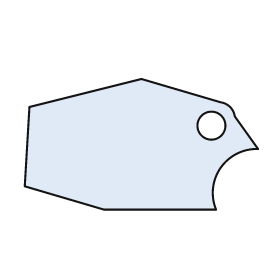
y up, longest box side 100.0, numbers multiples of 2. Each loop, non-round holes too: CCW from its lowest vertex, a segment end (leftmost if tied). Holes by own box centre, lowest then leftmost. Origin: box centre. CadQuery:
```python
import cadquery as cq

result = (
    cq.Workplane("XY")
    .moveTo(-16.0, -28.0)
    .lineTo(32.0, -28.0)
    .threePointArc((34.0, -10.0), (50.0, -2.0))
    .lineTo(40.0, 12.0)
    .threePointArc((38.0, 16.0), (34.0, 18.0))
    .lineTo(0.0, 28.0)
    .lineTo(-48.0, 16.0)
    .lineTo(-50.0, -18.0)
    .close()
    .moveTo(30.0, 8.0)
    .circle(6.0)
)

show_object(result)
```